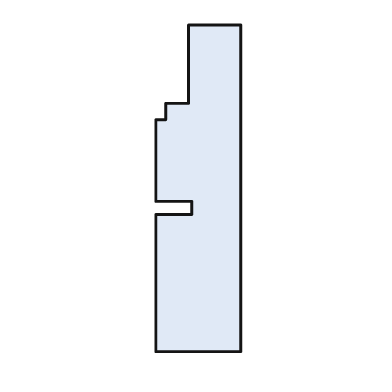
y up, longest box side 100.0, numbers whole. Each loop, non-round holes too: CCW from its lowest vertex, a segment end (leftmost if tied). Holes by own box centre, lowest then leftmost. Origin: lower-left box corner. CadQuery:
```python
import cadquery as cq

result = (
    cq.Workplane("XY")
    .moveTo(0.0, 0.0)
    .lineTo(26.0, 0.0)
    .lineTo(26.0, 100.0)
    .lineTo(10.0, 100.0)
    .lineTo(10.0, 76.0)
    .lineTo(3.0, 76.0)
    .lineTo(3.0, 71.0)
    .lineTo(0.0, 71.0)
    .lineTo(0.0, 46.0)
    .lineTo(11.0, 46.0)
    .lineTo(11.0, 42.0)
    .lineTo(0.0, 42.0)
    .close()
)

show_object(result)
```